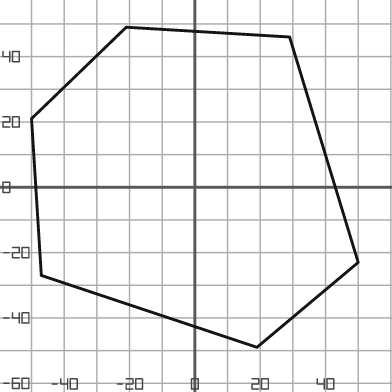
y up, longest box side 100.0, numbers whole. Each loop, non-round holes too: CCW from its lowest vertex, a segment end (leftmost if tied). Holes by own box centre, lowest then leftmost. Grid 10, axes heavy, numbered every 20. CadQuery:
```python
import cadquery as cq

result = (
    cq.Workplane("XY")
    .moveTo(19.0, -49.0)
    .lineTo(50.0, -23.0)
    .lineTo(29.0, 46.0)
    .lineTo(-21.0, 49.0)
    .lineTo(-50.0, 21.0)
    .lineTo(-47.0, -27.0)
    .close()
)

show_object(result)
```